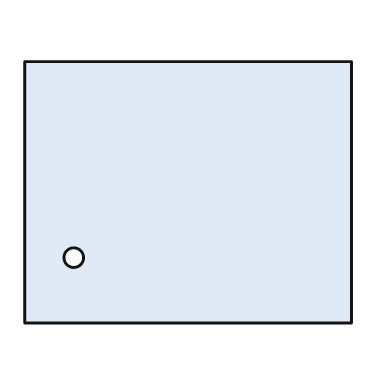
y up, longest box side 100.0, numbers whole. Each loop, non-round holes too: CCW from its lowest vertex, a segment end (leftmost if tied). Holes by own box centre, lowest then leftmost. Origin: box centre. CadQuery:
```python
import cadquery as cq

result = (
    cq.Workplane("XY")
    .moveTo(-50.0, -40.0)
    .lineTo(50.0, -40.0)
    .lineTo(50.0, 40.0)
    .lineTo(-50.0, 40.0)
    .close()
    .moveTo(-35.0, -20.0)
    .circle(3.0)
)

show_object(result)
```